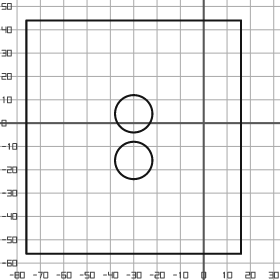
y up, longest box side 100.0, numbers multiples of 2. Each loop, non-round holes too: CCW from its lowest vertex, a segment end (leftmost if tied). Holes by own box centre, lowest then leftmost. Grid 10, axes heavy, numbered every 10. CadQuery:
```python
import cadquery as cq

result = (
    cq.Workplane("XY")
    .moveTo(-76.0, -56.0)
    .lineTo(16.0, -56.0)
    .lineTo(16.0, 44.0)
    .lineTo(-76.0, 44.0)
    .close()
    .moveTo(-30.0, -16.0)
    .circle(8.0)
    .moveTo(-30.0, 4.0)
    .circle(8.0)
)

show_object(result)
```